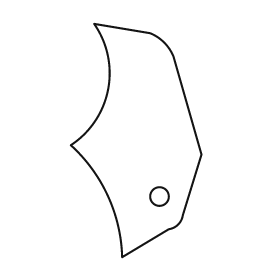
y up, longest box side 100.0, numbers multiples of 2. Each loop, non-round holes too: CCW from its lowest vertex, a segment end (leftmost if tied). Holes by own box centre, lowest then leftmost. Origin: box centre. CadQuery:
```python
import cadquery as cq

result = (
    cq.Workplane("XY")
    .moveTo(-6.0, -50.0)
    .lineTo(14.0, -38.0)
    .threePointArc((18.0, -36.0), (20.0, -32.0))
    .lineTo(28.0, -6.0)
    .lineTo(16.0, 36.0)
    .threePointArc((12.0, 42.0), (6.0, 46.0))
    .lineTo(-18.0, 50.0)
    .threePointArc((-12.0, 22.0), (-28.0, -2.0))
    .threePointArc((-12.0, -24.0), (-6.0, -50.0))
    .close()
    .moveTo(10.0, -24.0)
    .circle(4.0)
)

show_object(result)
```